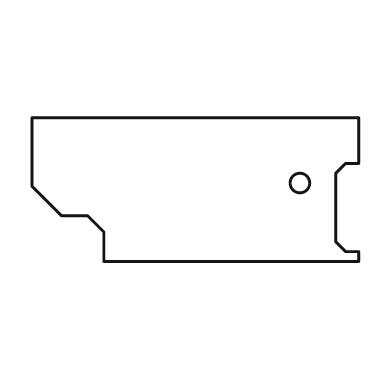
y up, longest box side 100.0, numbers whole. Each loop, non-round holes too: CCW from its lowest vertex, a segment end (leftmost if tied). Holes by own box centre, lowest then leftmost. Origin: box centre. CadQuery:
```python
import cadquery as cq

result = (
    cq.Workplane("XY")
    .moveTo(-28.0, -22.0)
    .lineTo(50.0, -22.0)
    .lineTo(50.0, -19.0)
    .lineTo(46.0, -19.0)
    .lineTo(43.0, -16.0)
    .lineTo(43.0, 5.0)
    .lineTo(46.0, 8.0)
    .lineTo(50.0, 8.0)
    .lineTo(50.0, 22.0)
    .lineTo(-50.0, 22.0)
    .lineTo(-50.0, 1.0)
    .lineTo(-41.0, -8.0)
    .lineTo(-33.0, -8.0)
    .lineTo(-28.0, -13.0)
    .close()
    .moveTo(32.0, 2.0)
    .circle(3.0)
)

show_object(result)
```